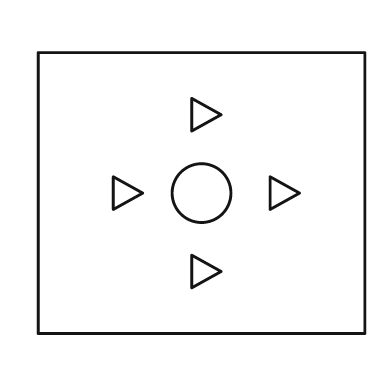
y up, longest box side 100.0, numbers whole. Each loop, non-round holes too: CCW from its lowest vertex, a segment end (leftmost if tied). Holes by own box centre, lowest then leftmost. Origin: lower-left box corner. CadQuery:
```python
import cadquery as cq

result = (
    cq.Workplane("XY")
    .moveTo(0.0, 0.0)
    .lineTo(100.0, 0.0)
    .lineTo(100.0, 86.0)
    .lineTo(0.0, 86.0)
    .close()
    .moveTo(47.0, 14.0)
    .lineTo(56.0, 19.0)
    .lineTo(47.0, 24.0)
    .close()
    .moveTo(23.0, 38.0)
    .lineTo(32.0, 43.0)
    .lineTo(23.0, 48.0)
    .close()
    .moveTo(50.0, 43.0)
    .circle(9.0)
    .moveTo(71.0, 38.0)
    .lineTo(80.0, 43.0)
    .lineTo(71.0, 48.0)
    .close()
    .moveTo(47.0, 62.0)
    .lineTo(56.0, 67.0)
    .lineTo(47.0, 72.0)
    .close()
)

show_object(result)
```